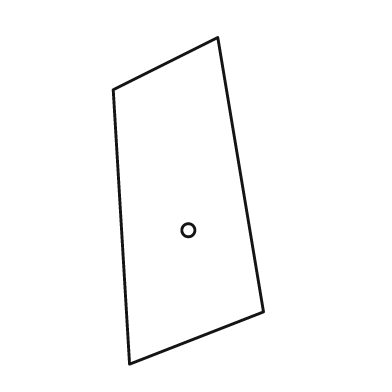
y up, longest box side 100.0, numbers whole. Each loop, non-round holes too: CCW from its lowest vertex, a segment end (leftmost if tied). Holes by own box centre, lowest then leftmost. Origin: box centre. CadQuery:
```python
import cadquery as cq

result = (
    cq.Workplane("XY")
    .moveTo(-18.0, -50.0)
    .lineTo(23.0, -34.0)
    .lineTo(9.0, 50.0)
    .lineTo(-23.0, 34.0)
    .close()
    .moveTo(0.0, -9.0)
    .circle(2.0)
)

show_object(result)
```